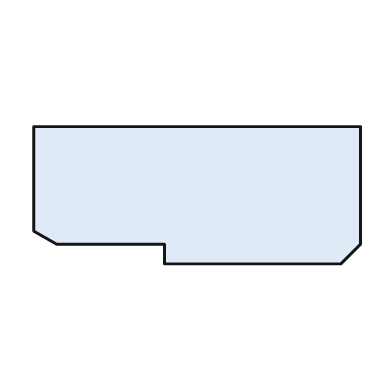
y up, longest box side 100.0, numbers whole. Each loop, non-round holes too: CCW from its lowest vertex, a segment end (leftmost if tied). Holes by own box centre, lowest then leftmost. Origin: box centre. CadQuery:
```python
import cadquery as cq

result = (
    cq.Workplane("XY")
    .moveTo(-10.0, -21.0)
    .lineTo(44.0, -21.0)
    .lineTo(50.0, -15.0)
    .lineTo(50.0, 21.0)
    .lineTo(-50.0, 21.0)
    .lineTo(-50.0, -11.0)
    .lineTo(-43.0, -15.0)
    .lineTo(-10.0, -15.0)
    .close()
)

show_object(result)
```